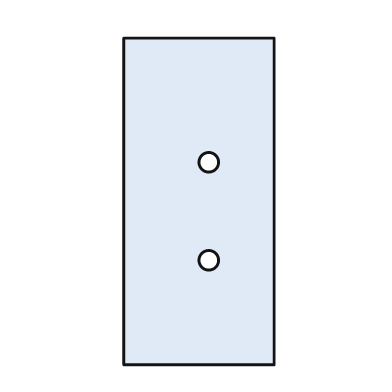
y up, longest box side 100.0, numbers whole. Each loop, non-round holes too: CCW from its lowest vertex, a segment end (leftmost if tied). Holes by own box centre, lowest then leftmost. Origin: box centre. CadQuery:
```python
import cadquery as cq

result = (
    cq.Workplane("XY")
    .moveTo(-23.0, -50.0)
    .lineTo(23.0, -50.0)
    .lineTo(23.0, 50.0)
    .lineTo(-23.0, 50.0)
    .close()
    .moveTo(3.0, -18.0)
    .circle(3.0)
    .moveTo(3.0, 12.0)
    .circle(3.0)
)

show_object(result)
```